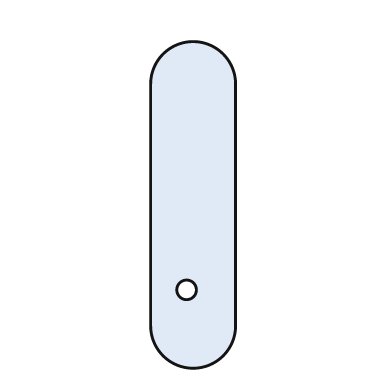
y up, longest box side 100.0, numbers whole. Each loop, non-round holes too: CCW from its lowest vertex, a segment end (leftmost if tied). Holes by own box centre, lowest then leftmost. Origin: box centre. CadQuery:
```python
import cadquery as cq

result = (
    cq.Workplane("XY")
    .moveTo(-13.0, -37.0)
    .threePointArc((0.0, -50.0), (13.0, -37.0))
    .lineTo(13.0, 37.0)
    .threePointArc((0.0, 50.0), (-13.0, 37.0))
    .close()
    .moveTo(-2.0, -26.0)
    .circle(3.0)
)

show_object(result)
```